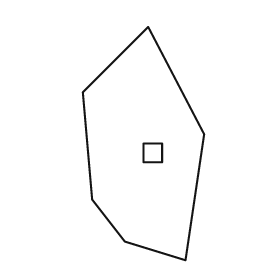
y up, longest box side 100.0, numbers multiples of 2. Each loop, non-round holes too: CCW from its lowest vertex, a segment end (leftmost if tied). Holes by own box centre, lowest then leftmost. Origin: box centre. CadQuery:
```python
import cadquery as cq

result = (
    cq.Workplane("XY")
    .moveTo(18.0, -50.0)
    .lineTo(26.0, 4.0)
    .lineTo(2.0, 50.0)
    .lineTo(-26.0, 22.0)
    .lineTo(-22.0, -24.0)
    .lineTo(-8.0, -42.0)
    .close()
    .moveTo(0.0, -8.0)
    .lineTo(8.0, -8.0)
    .lineTo(8.0, 0.0)
    .lineTo(0.0, 0.0)
    .close()
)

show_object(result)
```